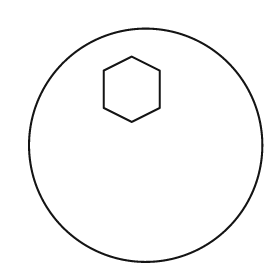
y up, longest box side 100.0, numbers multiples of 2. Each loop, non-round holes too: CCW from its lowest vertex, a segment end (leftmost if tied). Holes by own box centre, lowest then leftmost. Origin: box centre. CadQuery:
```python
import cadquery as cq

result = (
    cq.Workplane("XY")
    .moveTo(0.0, 0.0)
    .circle(50.0)
    .moveTo(-6.0, 10.0)
    .lineTo(6.0, 16.0)
    .lineTo(6.0, 32.0)
    .lineTo(-6.0, 38.0)
    .lineTo(-18.0, 32.0)
    .lineTo(-18.0, 16.0)
    .close()
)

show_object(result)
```